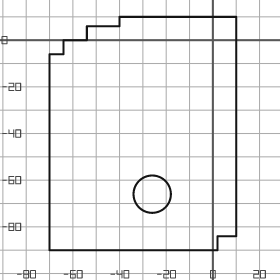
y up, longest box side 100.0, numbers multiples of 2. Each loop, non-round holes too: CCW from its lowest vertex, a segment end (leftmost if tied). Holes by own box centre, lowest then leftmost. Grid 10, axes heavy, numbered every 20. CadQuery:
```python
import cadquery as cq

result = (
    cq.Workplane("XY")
    .moveTo(-70.0, -90.0)
    .lineTo(2.0, -90.0)
    .lineTo(2.0, -84.0)
    .lineTo(10.0, -84.0)
    .lineTo(10.0, 10.0)
    .lineTo(-40.0, 10.0)
    .lineTo(-40.0, 6.0)
    .lineTo(-54.0, 6.0)
    .lineTo(-54.0, 0.0)
    .lineTo(-64.0, 0.0)
    .lineTo(-64.0, -6.0)
    .lineTo(-70.0, -6.0)
    .close()
    .moveTo(-26.0, -66.0)
    .circle(8.0)
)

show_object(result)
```